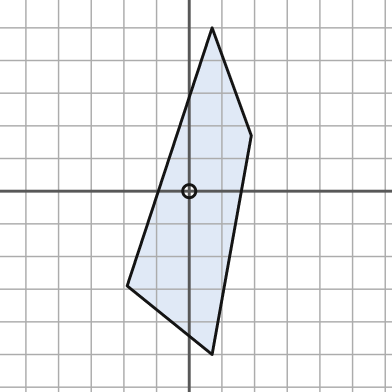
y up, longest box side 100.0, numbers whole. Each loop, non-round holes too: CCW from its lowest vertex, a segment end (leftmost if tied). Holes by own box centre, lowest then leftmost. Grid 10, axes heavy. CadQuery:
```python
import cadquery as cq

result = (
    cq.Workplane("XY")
    .moveTo(7.0, -50.0)
    .lineTo(19.0, 17.0)
    .lineTo(7.0, 50.0)
    .lineTo(-19.0, -29.0)
    .close()
    .moveTo(0.0, 0.0)
    .circle(2.0)
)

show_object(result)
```